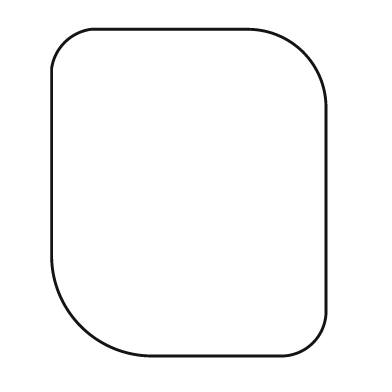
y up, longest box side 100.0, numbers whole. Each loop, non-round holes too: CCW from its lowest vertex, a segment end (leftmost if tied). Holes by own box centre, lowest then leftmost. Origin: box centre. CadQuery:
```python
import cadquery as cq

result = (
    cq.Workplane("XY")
    .moveTo(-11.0, -50.0)
    .lineTo(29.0, -50.0)
    .threePointArc((38.0, -46.0), (42.0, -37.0))
    .lineTo(42.0, 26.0)
    .threePointArc((35.0, 43.0), (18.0, 50.0))
    .lineTo(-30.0, 50.0)
    .threePointArc((-38.0, 46.0), (-42.0, 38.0))
    .lineTo(-42.0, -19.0)
    .threePointArc((-33.0, -41.0), (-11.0, -50.0))
    .close()
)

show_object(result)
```